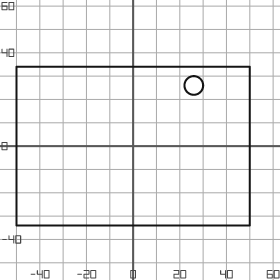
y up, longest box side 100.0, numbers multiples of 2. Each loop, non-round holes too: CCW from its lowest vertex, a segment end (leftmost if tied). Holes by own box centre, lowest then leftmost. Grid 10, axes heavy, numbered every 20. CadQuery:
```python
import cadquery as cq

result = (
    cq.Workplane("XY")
    .moveTo(-50.0, -34.0)
    .lineTo(50.0, -34.0)
    .lineTo(50.0, 34.0)
    .lineTo(-50.0, 34.0)
    .close()
    .moveTo(26.0, 26.0)
    .circle(4.0)
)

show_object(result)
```